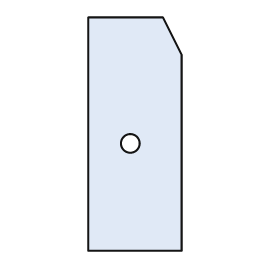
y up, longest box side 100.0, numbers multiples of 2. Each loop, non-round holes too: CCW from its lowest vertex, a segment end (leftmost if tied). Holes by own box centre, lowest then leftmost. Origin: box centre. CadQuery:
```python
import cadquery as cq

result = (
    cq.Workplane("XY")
    .moveTo(-20.0, -50.0)
    .lineTo(20.0, -50.0)
    .lineTo(20.0, 34.0)
    .lineTo(12.0, 50.0)
    .lineTo(-20.0, 50.0)
    .close()
    .moveTo(-2.0, -4.0)
    .circle(4.0)
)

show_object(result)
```